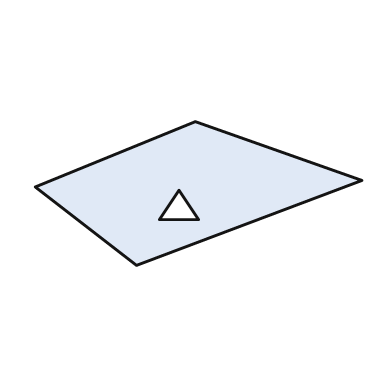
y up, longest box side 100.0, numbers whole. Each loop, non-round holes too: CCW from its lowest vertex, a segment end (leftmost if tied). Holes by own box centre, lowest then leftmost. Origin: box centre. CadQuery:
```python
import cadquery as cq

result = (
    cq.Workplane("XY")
    .moveTo(-19.0, -22.0)
    .lineTo(50.0, 4.0)
    .lineTo(-1.0, 22.0)
    .lineTo(-50.0, 2.0)
    .close()
    .moveTo(-12.0, -8.0)
    .lineTo(0.0, -8.0)
    .lineTo(-6.0, 1.0)
    .close()
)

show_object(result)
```